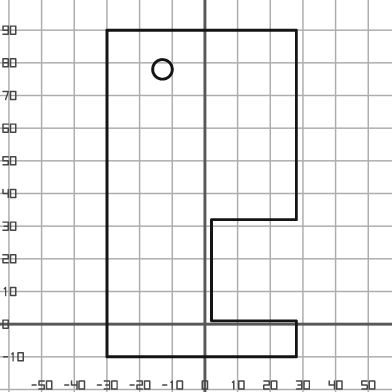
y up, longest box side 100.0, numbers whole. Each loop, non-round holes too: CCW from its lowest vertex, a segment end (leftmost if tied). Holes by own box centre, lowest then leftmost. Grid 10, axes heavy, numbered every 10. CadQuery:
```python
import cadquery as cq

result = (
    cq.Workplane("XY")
    .moveTo(-30.0, -10.0)
    .lineTo(28.0, -10.0)
    .lineTo(28.0, 1.0)
    .lineTo(2.0, 1.0)
    .lineTo(2.0, 32.0)
    .lineTo(28.0, 32.0)
    .lineTo(28.0, 90.0)
    .lineTo(-30.0, 90.0)
    .close()
    .moveTo(-13.0, 78.0)
    .circle(3.0)
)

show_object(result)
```